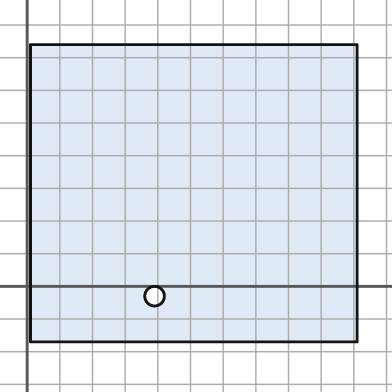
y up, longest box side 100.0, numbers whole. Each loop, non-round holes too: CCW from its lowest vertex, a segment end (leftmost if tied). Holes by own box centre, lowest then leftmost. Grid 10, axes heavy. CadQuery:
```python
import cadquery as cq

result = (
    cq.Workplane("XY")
    .moveTo(1.0, -17.0)
    .lineTo(101.0, -17.0)
    .lineTo(101.0, 74.0)
    .lineTo(1.0, 74.0)
    .close()
    .moveTo(39.0, -3.0)
    .circle(3.0)
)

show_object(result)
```